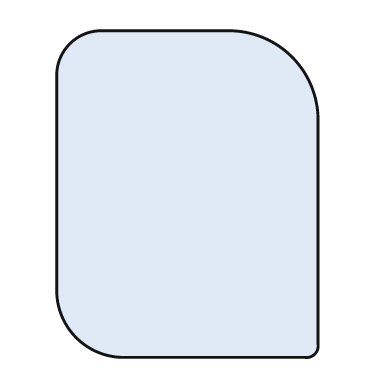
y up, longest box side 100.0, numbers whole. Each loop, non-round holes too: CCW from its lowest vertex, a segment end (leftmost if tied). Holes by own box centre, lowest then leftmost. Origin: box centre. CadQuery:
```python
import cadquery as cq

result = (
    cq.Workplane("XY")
    .moveTo(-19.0, -50.0)
    .lineTo(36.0, -50.0)
    .threePointArc((39.0, -49.0), (40.0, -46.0))
    .lineTo(40.0, 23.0)
    .threePointArc((32.0, 42.0), (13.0, 50.0))
    .lineTo(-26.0, 50.0)
    .threePointArc((-36.0, 46.0), (-40.0, 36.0))
    .lineTo(-40.0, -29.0)
    .threePointArc((-34.0, -44.0), (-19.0, -50.0))
    .close()
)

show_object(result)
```